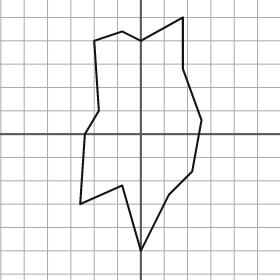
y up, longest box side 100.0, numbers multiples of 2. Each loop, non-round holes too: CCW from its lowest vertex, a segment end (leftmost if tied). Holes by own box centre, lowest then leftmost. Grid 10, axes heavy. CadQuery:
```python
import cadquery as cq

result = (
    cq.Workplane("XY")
    .moveTo(0.0, -50.0)
    .lineTo(12.0, -26.0)
    .lineTo(22.0, -16.0)
    .lineTo(26.0, 6.0)
    .lineTo(18.0, 28.0)
    .lineTo(18.0, 50.0)
    .lineTo(0.0, 40.0)
    .lineTo(-8.0, 44.0)
    .lineTo(-20.0, 40.0)
    .lineTo(-18.0, 10.0)
    .lineTo(-24.0, 0.0)
    .lineTo(-26.0, -30.0)
    .lineTo(-8.0, -22.0)
    .close()
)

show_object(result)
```